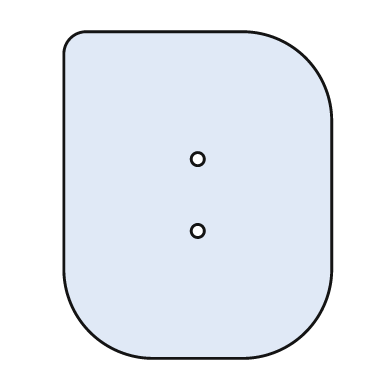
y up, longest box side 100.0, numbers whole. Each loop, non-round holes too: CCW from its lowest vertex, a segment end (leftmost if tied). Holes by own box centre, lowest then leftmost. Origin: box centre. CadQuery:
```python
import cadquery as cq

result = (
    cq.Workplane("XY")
    .moveTo(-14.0, -50.0)
    .lineTo(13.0, -50.0)
    .threePointArc((33.0, -42.0), (41.0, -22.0))
    .lineTo(41.0, 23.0)
    .threePointArc((33.0, 42.0), (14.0, 50.0))
    .lineTo(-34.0, 50.0)
    .threePointArc((-39.0, 48.0), (-41.0, 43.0))
    .lineTo(-41.0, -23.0)
    .threePointArc((-33.0, -42.0), (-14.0, -50.0))
    .close()
    .moveTo(0.0, -11.0)
    .circle(2.0)
    .moveTo(0.0, 11.0)
    .circle(2.0)
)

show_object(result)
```